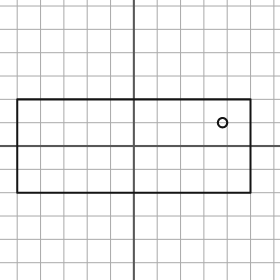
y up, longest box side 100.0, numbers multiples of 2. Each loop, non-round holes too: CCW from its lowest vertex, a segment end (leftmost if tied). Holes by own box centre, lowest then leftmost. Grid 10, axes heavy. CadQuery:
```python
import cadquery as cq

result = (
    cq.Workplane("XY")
    .moveTo(-50.0, -20.0)
    .lineTo(50.0, -20.0)
    .lineTo(50.0, 20.0)
    .lineTo(-50.0, 20.0)
    .close()
    .moveTo(38.0, 10.0)
    .circle(2.0)
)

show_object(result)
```